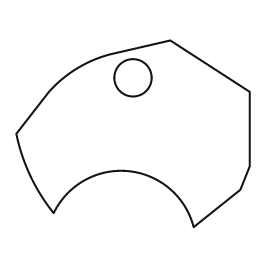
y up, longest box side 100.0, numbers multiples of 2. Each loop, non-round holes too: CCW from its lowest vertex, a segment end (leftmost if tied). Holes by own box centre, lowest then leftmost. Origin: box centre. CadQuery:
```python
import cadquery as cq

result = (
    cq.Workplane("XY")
    .moveTo(26.0, -40.0)
    .lineTo(46.0, -24.0)
    .lineTo(50.0, -14.0)
    .lineTo(50.0, 18.0)
    .lineTo(16.0, 40.0)
    .lineTo(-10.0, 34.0)
    .threePointArc((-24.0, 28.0), (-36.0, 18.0))
    .lineTo(-50.0, 0.0)
    .threePointArc((-44.0, -18.0), (-34.0, -34.0))
    .threePointArc((-2.0, -16.0), (26.0, -40.0))
    .close()
    .moveTo(0.0, 24.0)
    .circle(8.0)
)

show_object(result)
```